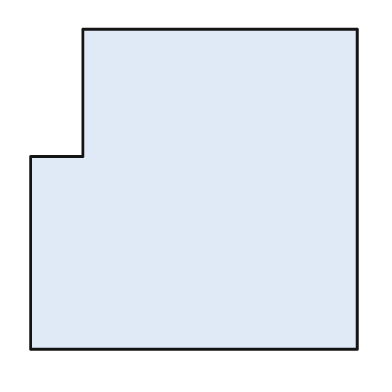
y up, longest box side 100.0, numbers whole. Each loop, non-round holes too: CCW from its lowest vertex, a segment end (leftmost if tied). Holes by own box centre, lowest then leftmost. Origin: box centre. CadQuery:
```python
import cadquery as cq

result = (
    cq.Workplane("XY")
    .moveTo(-50.0, -49.0)
    .lineTo(50.0, -49.0)
    .lineTo(50.0, 49.0)
    .lineTo(-34.0, 49.0)
    .lineTo(-34.0, 10.0)
    .lineTo(-50.0, 10.0)
    .close()
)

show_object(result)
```